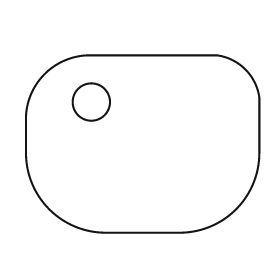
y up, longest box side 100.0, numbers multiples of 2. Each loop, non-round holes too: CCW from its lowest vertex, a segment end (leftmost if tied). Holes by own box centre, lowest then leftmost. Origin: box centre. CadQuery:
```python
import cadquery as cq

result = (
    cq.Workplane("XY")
    .moveTo(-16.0, -38.0)
    .lineTo(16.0, -38.0)
    .threePointArc((40.0, -28.0), (50.0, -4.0))
    .lineTo(50.0, 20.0)
    .threePointArc((44.0, 32.0), (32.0, 38.0))
    .lineTo(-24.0, 38.0)
    .threePointArc((-42.0, 30.0), (-50.0, 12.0))
    .lineTo(-50.0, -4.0)
    .threePointArc((-40.0, -28.0), (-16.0, -38.0))
    .close()
    .moveTo(-22.0, 18.0)
    .circle(8.0)
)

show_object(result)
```